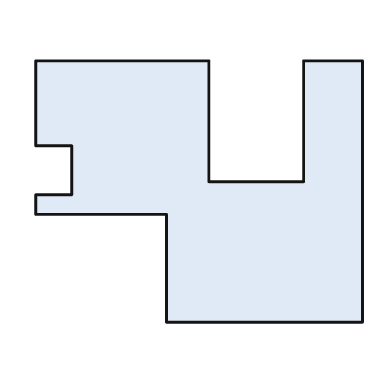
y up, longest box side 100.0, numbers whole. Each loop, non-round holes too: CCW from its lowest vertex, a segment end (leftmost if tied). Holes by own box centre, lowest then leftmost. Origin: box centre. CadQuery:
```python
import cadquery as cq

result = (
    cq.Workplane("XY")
    .moveTo(-10.0, -40.0)
    .lineTo(50.0, -40.0)
    .lineTo(50.0, 40.0)
    .lineTo(32.0, 40.0)
    .lineTo(32.0, 3.0)
    .lineTo(3.0, 3.0)
    .lineTo(3.0, 40.0)
    .lineTo(-50.0, 40.0)
    .lineTo(-50.0, 14.0)
    .lineTo(-39.0, 14.0)
    .lineTo(-39.0, -1.0)
    .lineTo(-50.0, -1.0)
    .lineTo(-50.0, -7.0)
    .lineTo(-10.0, -7.0)
    .close()
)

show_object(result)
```